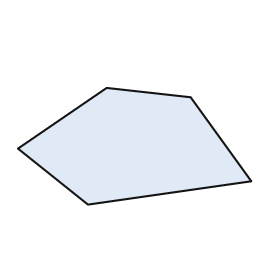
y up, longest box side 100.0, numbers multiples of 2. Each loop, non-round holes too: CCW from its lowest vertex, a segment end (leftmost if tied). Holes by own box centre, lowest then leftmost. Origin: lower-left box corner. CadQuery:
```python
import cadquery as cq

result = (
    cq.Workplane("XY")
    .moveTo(30.0, 0.0)
    .lineTo(100.0, 10.0)
    .lineTo(74.0, 46.0)
    .lineTo(38.0, 50.0)
    .lineTo(0.0, 24.0)
    .close()
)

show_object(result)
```